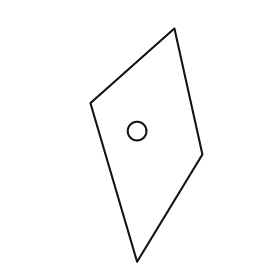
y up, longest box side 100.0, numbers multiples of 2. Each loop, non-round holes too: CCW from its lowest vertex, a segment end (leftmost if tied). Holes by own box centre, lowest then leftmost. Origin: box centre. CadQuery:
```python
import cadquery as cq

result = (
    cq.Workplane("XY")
    .moveTo(-4.0, -50.0)
    .lineTo(24.0, -4.0)
    .lineTo(12.0, 50.0)
    .lineTo(-24.0, 18.0)
    .close()
    .moveTo(-4.0, 6.0)
    .circle(4.0)
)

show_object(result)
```